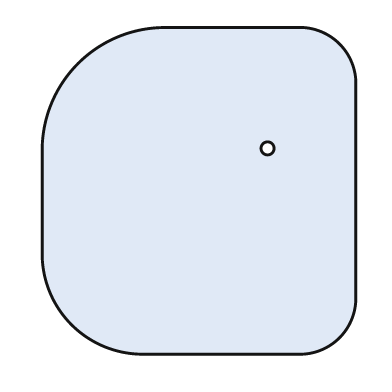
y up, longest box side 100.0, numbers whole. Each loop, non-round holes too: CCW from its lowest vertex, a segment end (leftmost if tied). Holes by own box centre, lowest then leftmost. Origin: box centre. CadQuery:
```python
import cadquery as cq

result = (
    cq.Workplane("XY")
    .moveTo(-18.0, -50.0)
    .lineTo(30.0, -50.0)
    .threePointArc((43.0, -45.0), (48.0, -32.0))
    .lineTo(48.0, 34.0)
    .threePointArc((43.0, 45.0), (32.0, 50.0))
    .lineTo(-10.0, 50.0)
    .threePointArc((-37.0, 39.0), (-48.0, 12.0))
    .lineTo(-48.0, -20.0)
    .threePointArc((-39.0, -41.0), (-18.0, -50.0))
    .close()
    .moveTo(21.0, 13.0)
    .circle(2.0)
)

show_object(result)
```